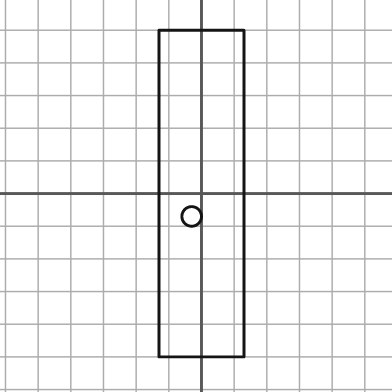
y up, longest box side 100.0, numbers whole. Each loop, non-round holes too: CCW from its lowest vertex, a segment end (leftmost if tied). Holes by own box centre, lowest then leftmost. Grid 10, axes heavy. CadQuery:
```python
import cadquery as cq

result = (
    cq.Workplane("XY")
    .moveTo(-13.0, -50.0)
    .lineTo(13.0, -50.0)
    .lineTo(13.0, 50.0)
    .lineTo(-13.0, 50.0)
    .close()
    .moveTo(-3.0, -7.0)
    .circle(3.0)
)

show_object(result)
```